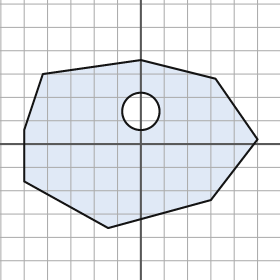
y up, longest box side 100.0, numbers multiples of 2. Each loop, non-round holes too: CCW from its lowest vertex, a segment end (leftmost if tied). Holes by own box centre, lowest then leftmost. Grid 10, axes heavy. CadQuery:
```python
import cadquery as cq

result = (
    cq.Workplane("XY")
    .moveTo(-14.0, -36.0)
    .lineTo(30.0, -24.0)
    .lineTo(50.0, 2.0)
    .lineTo(32.0, 28.0)
    .lineTo(0.0, 36.0)
    .lineTo(-42.0, 30.0)
    .lineTo(-50.0, 6.0)
    .lineTo(-50.0, -16.0)
    .close()
    .moveTo(0.0, 14.0)
    .circle(8.0)
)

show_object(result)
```